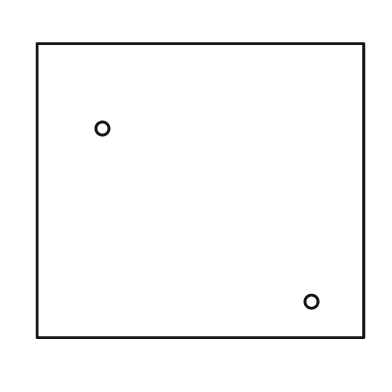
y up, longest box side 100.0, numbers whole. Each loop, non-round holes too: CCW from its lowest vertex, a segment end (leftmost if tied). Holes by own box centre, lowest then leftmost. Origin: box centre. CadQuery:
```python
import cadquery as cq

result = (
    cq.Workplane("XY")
    .moveTo(-50.0, -45.0)
    .lineTo(50.0, -45.0)
    .lineTo(50.0, 45.0)
    .lineTo(-50.0, 45.0)
    .close()
    .moveTo(34.0, -34.0)
    .circle(2.0)
    .moveTo(-30.0, 19.0)
    .circle(2.0)
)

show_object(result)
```